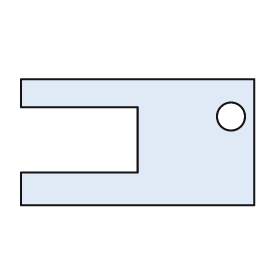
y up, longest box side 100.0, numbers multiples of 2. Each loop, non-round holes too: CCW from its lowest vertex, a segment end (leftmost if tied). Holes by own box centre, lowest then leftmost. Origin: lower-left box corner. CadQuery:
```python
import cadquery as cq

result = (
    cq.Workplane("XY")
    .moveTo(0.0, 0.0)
    .lineTo(100.0, 0.0)
    .lineTo(100.0, 54.0)
    .lineTo(0.0, 54.0)
    .lineTo(0.0, 42.0)
    .lineTo(50.0, 42.0)
    .lineTo(50.0, 14.0)
    .lineTo(0.0, 14.0)
    .close()
    .moveTo(90.0, 38.0)
    .circle(6.0)
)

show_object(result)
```